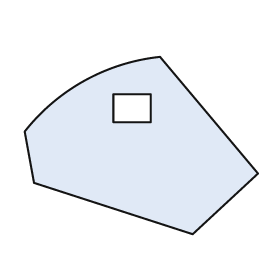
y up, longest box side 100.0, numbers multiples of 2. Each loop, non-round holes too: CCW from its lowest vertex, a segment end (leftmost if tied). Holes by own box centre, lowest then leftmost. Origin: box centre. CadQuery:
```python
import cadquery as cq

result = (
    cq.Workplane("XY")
    .moveTo(22.0, -38.0)
    .lineTo(50.0, -12.0)
    .lineTo(8.0, 38.0)
    .threePointArc((-24.0, 28.0), (-50.0, 6.0))
    .lineTo(-46.0, -16.0)
    .close()
    .moveTo(-12.0, 10.0)
    .lineTo(4.0, 10.0)
    .lineTo(4.0, 22.0)
    .lineTo(-12.0, 22.0)
    .close()
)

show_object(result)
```